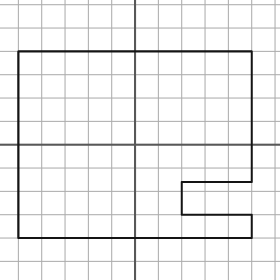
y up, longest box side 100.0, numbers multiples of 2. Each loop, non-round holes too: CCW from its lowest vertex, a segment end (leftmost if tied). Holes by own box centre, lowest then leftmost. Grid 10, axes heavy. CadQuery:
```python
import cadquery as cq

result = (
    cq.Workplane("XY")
    .moveTo(-50.0, -40.0)
    .lineTo(50.0, -40.0)
    .lineTo(50.0, -30.0)
    .lineTo(20.0, -30.0)
    .lineTo(20.0, -16.0)
    .lineTo(50.0, -16.0)
    .lineTo(50.0, 40.0)
    .lineTo(-50.0, 40.0)
    .close()
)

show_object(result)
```